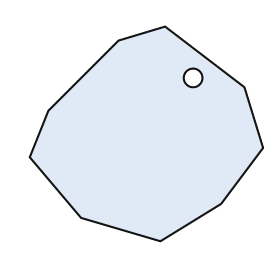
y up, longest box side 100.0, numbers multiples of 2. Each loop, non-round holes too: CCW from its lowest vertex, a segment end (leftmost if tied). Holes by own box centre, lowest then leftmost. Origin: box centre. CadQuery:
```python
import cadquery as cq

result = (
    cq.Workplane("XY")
    .moveTo(6.0, -46.0)
    .lineTo(32.0, -30.0)
    .lineTo(50.0, -6.0)
    .lineTo(42.0, 20.0)
    .lineTo(8.0, 46.0)
    .lineTo(-12.0, 40.0)
    .lineTo(-42.0, 10.0)
    .lineTo(-50.0, -10.0)
    .lineTo(-28.0, -36.0)
    .close()
    .moveTo(20.0, 24.0)
    .circle(4.0)
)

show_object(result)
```